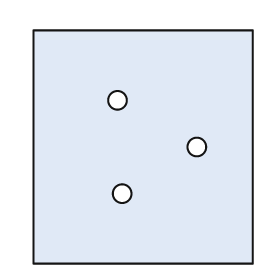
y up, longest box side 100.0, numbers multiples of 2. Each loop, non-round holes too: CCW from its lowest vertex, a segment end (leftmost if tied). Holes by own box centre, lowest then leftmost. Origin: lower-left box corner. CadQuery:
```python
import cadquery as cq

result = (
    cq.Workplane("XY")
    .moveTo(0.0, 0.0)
    .lineTo(94.0, 0.0)
    .lineTo(94.0, 100.0)
    .lineTo(0.0, 100.0)
    .close()
    .moveTo(38.0, 30.0)
    .circle(4.0)
    .moveTo(70.0, 50.0)
    .circle(4.0)
    .moveTo(36.0, 70.0)
    .circle(4.0)
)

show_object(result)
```